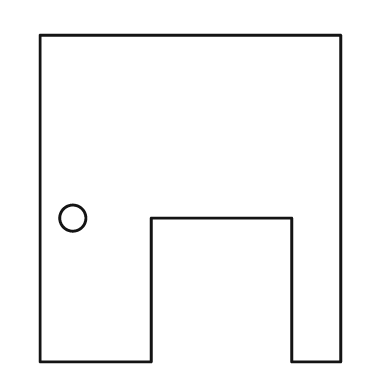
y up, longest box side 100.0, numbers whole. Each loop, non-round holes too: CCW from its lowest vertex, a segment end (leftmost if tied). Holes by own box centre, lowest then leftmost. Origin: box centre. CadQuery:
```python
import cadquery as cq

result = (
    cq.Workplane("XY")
    .moveTo(-46.0, -50.0)
    .lineTo(-12.0, -50.0)
    .lineTo(-12.0, -6.0)
    .lineTo(31.0, -6.0)
    .lineTo(31.0, -50.0)
    .lineTo(46.0, -50.0)
    .lineTo(46.0, 50.0)
    .lineTo(-46.0, 50.0)
    .close()
    .moveTo(-36.0, -6.0)
    .circle(4.0)
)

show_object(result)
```